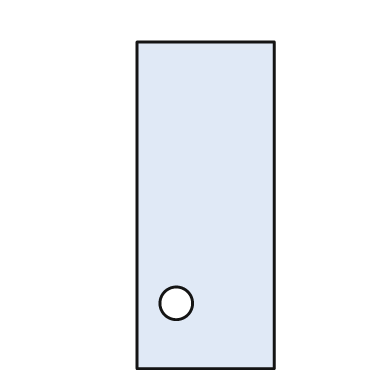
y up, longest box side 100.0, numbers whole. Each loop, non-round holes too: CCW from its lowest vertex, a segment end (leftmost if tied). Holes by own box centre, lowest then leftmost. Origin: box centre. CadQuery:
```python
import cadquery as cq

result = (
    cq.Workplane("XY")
    .moveTo(-21.0, -50.0)
    .lineTo(21.0, -50.0)
    .lineTo(21.0, 50.0)
    .lineTo(-21.0, 50.0)
    .close()
    .moveTo(-9.0, -30.0)
    .circle(5.0)
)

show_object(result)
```